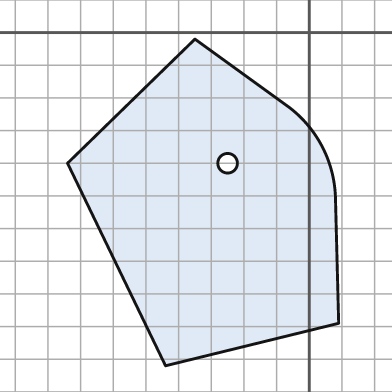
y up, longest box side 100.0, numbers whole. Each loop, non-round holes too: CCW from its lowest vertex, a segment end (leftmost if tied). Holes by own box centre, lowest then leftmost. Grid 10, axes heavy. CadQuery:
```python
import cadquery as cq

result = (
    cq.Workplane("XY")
    .moveTo(-44.0, -102.0)
    .lineTo(9.0, -89.0)
    .lineTo(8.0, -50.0)
    .threePointArc((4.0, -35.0), (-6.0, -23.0))
    .lineTo(-35.0, -2.0)
    .lineTo(-74.0, -40.0)
    .close()
    .moveTo(-25.0, -40.0)
    .circle(3.0)
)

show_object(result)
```